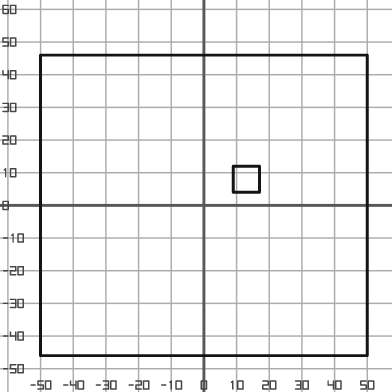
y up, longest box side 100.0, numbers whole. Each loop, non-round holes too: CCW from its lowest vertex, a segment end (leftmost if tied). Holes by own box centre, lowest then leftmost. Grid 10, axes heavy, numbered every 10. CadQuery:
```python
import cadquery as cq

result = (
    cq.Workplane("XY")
    .moveTo(-50.0, -46.0)
    .lineTo(50.0, -46.0)
    .lineTo(50.0, 46.0)
    .lineTo(-50.0, 46.0)
    .close()
    .moveTo(9.0, 4.0)
    .lineTo(17.0, 4.0)
    .lineTo(17.0, 12.0)
    .lineTo(9.0, 12.0)
    .close()
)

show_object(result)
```